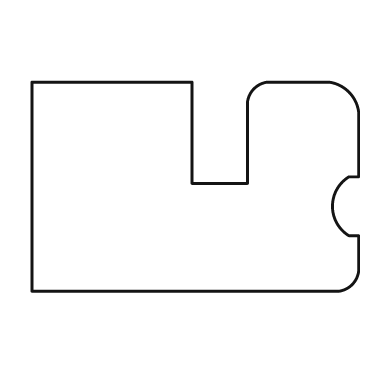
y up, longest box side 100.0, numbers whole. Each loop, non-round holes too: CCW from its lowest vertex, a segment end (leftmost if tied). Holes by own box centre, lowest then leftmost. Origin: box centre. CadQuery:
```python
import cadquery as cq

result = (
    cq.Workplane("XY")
    .moveTo(-50.0, -32.0)
    .lineTo(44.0, -32.0)
    .threePointArc((48.0, -30.0), (50.0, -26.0))
    .lineTo(50.0, -15.0)
    .lineTo(47.0, -15.0)
    .threePointArc((42.0, -6.0), (47.0, 3.0))
    .lineTo(50.0, 3.0)
    .lineTo(50.0, 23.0)
    .threePointArc((47.0, 29.0), (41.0, 32.0))
    .lineTo(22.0, 32.0)
    .threePointArc((18.0, 30.0), (16.0, 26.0))
    .lineTo(16.0, 1.0)
    .lineTo(-1.0, 1.0)
    .lineTo(-1.0, 32.0)
    .lineTo(-50.0, 32.0)
    .close()
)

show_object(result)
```